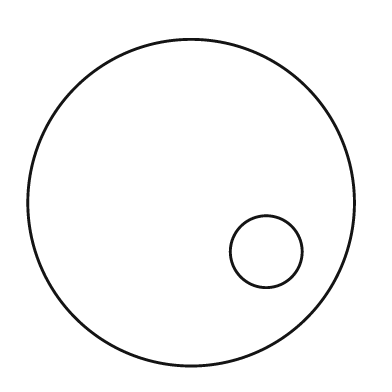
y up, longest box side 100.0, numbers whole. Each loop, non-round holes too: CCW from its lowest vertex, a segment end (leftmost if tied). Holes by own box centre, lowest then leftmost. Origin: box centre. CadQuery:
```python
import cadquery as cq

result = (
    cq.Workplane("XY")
    .moveTo(0.0, 0.0)
    .circle(50.0)
    .moveTo(23.0, -15.0)
    .circle(11.0)
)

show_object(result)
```